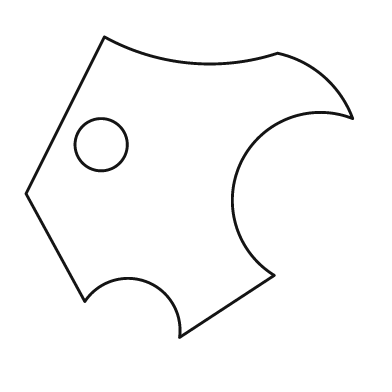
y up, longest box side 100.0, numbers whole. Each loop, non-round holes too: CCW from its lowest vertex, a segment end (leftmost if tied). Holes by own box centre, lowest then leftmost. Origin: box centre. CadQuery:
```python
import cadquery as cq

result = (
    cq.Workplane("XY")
    .moveTo(-3.0, -46.0)
    .lineTo(26.0, -27.0)
    .threePointArc((16.0, 8.0), (50.0, 21.0))
    .threePointArc((41.0, 34.0), (27.0, 41.0))
    .threePointArc((0.0, 38.0), (-26.0, 46.0))
    .lineTo(-50.0, -2.0)
    .lineTo(-32.0, -35.0)
    .threePointArc((-13.0, -29.0), (-3.0, -46.0))
    .close()
    .moveTo(-27.0, 13.0)
    .circle(8.0)
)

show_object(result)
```